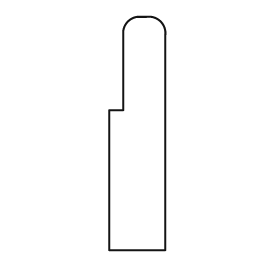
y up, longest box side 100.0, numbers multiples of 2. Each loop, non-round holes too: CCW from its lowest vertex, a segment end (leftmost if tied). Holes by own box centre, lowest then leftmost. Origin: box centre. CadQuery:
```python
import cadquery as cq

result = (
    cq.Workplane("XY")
    .moveTo(-12.0, -50.0)
    .lineTo(12.0, -50.0)
    .lineTo(12.0, 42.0)
    .threePointArc((10.0, 48.0), (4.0, 50.0))
    .lineTo(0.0, 50.0)
    .threePointArc((-4.0, 48.0), (-6.0, 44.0))
    .lineTo(-6.0, 10.0)
    .lineTo(-12.0, 10.0)
    .close()
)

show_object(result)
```